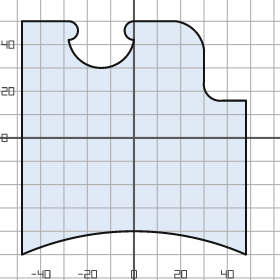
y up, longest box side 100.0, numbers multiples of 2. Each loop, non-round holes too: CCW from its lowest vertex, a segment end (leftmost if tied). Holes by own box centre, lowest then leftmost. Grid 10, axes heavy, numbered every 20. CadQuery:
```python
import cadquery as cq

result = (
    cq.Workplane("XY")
    .moveTo(-48.0, -50.0)
    .threePointArc((0.0, -40.0), (48.0, -50.0))
    .lineTo(48.0, 16.0)
    .lineTo(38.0, 16.0)
    .threePointArc((32.0, 18.0), (30.0, 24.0))
    .lineTo(30.0, 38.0)
    .threePointArc((26.0, 46.0), (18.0, 50.0))
    .lineTo(0.0, 50.0)
    .threePointArc((-4.0, 46.0), (0.0, 42.0))
    .threePointArc((-14.0, 30.0), (-28.0, 42.0))
    .threePointArc((-24.0, 46.0), (-28.0, 50.0))
    .lineTo(-48.0, 50.0)
    .close()
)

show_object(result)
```